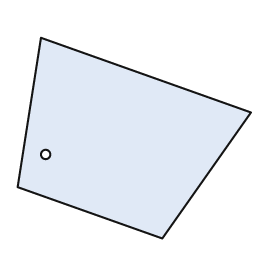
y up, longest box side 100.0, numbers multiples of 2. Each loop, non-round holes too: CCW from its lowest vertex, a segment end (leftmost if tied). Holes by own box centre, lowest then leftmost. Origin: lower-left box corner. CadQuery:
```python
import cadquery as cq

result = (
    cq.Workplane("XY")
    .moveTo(62.0, 0.0)
    .lineTo(100.0, 54.0)
    .lineTo(10.0, 86.0)
    .lineTo(0.0, 22.0)
    .close()
    .moveTo(12.0, 36.0)
    .circle(2.0)
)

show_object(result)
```